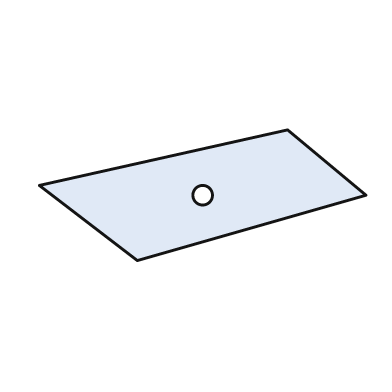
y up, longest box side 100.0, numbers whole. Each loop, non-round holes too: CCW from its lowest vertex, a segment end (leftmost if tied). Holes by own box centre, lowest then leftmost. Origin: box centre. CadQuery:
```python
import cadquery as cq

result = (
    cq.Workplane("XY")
    .moveTo(-20.0, -20.0)
    .lineTo(50.0, 0.0)
    .lineTo(26.0, 20.0)
    .lineTo(-50.0, 3.0)
    .close()
    .moveTo(0.0, 0.0)
    .circle(3.0)
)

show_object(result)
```